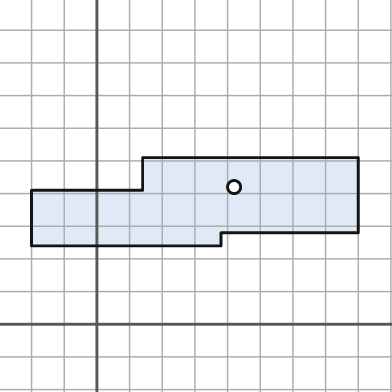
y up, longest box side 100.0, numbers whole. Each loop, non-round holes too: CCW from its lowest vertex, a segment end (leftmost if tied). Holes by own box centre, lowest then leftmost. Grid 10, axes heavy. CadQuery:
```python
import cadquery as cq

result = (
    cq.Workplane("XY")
    .moveTo(-20.0, 24.0)
    .lineTo(38.0, 24.0)
    .lineTo(38.0, 28.0)
    .lineTo(80.0, 28.0)
    .lineTo(80.0, 51.0)
    .lineTo(14.0, 51.0)
    .lineTo(14.0, 41.0)
    .lineTo(-20.0, 41.0)
    .close()
    .moveTo(42.0, 42.0)
    .circle(2.0)
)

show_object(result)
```